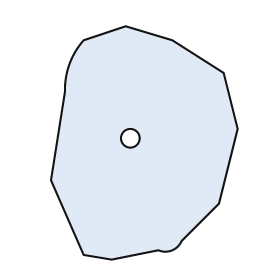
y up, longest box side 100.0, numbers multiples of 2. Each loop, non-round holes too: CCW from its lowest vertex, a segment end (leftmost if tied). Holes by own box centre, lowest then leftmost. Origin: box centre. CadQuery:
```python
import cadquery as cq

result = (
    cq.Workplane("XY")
    .moveTo(-14.0, -50.0)
    .lineTo(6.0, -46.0)
    .threePointArc((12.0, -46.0), (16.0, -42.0))
    .lineTo(32.0, -26.0)
    .lineTo(40.0, 6.0)
    .lineTo(34.0, 30.0)
    .lineTo(12.0, 44.0)
    .lineTo(-8.0, 50.0)
    .lineTo(-26.0, 44.0)
    .threePointArc((-32.0, 34.0), (-34.0, 22.0))
    .lineTo(-40.0, -16.0)
    .lineTo(-26.0, -48.0)
    .close()
    .moveTo(-6.0, 2.0)
    .circle(4.0)
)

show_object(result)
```